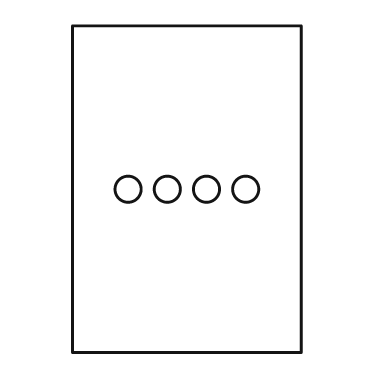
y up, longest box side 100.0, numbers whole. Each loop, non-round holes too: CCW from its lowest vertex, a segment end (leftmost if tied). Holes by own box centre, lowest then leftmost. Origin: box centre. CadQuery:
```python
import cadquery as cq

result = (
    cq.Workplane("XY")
    .moveTo(-35.0, -50.0)
    .lineTo(35.0, -50.0)
    .lineTo(35.0, 50.0)
    .lineTo(-35.0, 50.0)
    .close()
    .moveTo(-18.0, 0.0)
    .circle(4.0)
    .moveTo(-6.0, 0.0)
    .circle(4.0)
    .moveTo(6.0, 0.0)
    .circle(4.0)
    .moveTo(18.0, 0.0)
    .circle(4.0)
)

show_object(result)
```